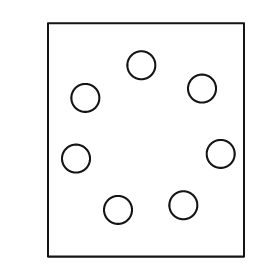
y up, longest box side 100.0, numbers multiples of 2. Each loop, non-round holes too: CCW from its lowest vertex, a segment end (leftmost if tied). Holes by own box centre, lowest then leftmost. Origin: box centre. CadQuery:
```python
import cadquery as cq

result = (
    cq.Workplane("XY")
    .moveTo(-42.0, -50.0)
    .lineTo(42.0, -50.0)
    .lineTo(42.0, 50.0)
    .lineTo(-42.0, 50.0)
    .close()
    .moveTo(-12.0, -30.0)
    .circle(6.0)
    .moveTo(16.0, -28.0)
    .circle(6.0)
    .moveTo(-30.0, -8.0)
    .circle(6.0)
    .moveTo(32.0, -6.0)
    .circle(6.0)
    .moveTo(-26.0, 18.0)
    .circle(6.0)
    .moveTo(24.0, 22.0)
    .circle(6.0)
    .moveTo(-2.0, 32.0)
    .circle(6.0)
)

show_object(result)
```